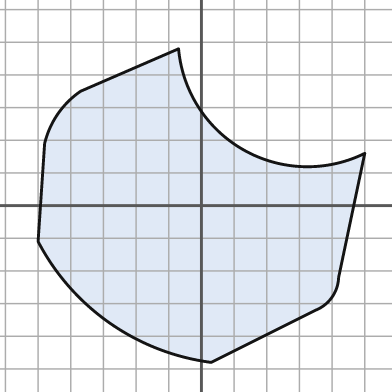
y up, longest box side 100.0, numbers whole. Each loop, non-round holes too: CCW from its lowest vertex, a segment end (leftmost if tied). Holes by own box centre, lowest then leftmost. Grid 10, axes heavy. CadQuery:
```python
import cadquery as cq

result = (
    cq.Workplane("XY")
    .moveTo(3.0, -48.0)
    .lineTo(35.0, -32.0)
    .threePointArc((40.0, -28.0), (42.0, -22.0))
    .lineTo(50.0, 16.0)
    .threePointArc((13.0, 17.0), (-7.0, 48.0))
    .lineTo(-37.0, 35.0)
    .threePointArc((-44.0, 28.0), (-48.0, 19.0))
    .lineTo(-50.0, -11.0)
    .threePointArc((-28.0, -36.0), (3.0, -48.0))
    .close()
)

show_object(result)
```